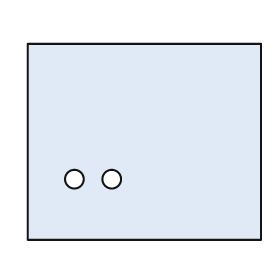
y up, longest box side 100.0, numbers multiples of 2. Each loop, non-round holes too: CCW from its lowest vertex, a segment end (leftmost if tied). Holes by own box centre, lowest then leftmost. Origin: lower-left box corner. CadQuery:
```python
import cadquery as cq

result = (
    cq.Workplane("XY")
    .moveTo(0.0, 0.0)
    .lineTo(100.0, 0.0)
    .lineTo(100.0, 84.0)
    .lineTo(0.0, 84.0)
    .close()
    .moveTo(20.0, 26.0)
    .circle(4.0)
    .moveTo(36.0, 26.0)
    .circle(4.0)
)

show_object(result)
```